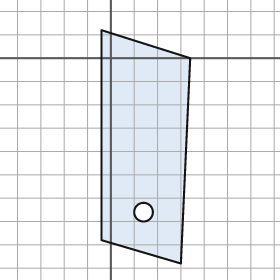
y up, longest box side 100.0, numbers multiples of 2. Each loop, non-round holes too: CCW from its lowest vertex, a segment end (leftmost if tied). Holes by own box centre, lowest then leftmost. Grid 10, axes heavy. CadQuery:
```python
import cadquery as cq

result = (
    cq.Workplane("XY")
    .moveTo(30.0, -88.0)
    .lineTo(34.0, 0.0)
    .lineTo(-4.0, 12.0)
    .lineTo(-4.0, -78.0)
    .close()
    .moveTo(14.0, -66.0)
    .circle(4.0)
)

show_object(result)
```